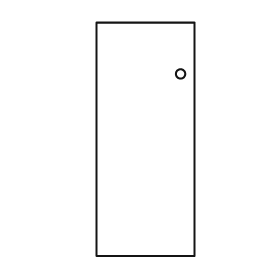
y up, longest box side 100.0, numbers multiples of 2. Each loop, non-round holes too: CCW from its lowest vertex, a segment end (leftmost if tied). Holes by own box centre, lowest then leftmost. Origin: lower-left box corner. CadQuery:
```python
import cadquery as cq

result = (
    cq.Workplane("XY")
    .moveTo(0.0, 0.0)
    .lineTo(42.0, 0.0)
    .lineTo(42.0, 100.0)
    .lineTo(0.0, 100.0)
    .close()
    .moveTo(36.0, 78.0)
    .circle(2.0)
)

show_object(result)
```